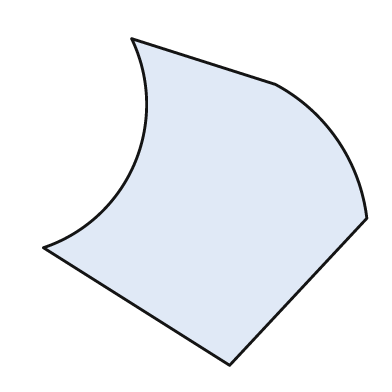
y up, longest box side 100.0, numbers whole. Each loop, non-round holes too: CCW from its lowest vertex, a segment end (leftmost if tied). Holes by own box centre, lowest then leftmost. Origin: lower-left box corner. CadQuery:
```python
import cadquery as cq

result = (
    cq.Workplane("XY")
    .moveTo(57.0, 0.0)
    .lineTo(99.0, 45.0)
    .threePointArc((90.0, 69.0), (71.0, 86.0))
    .lineTo(27.0, 100.0)
    .threePointArc((28.0, 62.0), (0.0, 36.0))
    .close()
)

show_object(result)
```